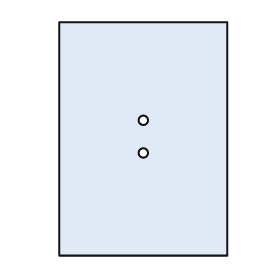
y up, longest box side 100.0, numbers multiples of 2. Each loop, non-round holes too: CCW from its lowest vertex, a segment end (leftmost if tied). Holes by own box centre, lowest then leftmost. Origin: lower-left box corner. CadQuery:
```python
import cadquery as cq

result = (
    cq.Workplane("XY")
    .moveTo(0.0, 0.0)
    .lineTo(72.0, 0.0)
    .lineTo(72.0, 100.0)
    .lineTo(0.0, 100.0)
    .close()
    .moveTo(36.0, 44.0)
    .circle(2.0)
    .moveTo(36.0, 58.0)
    .circle(2.0)
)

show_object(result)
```